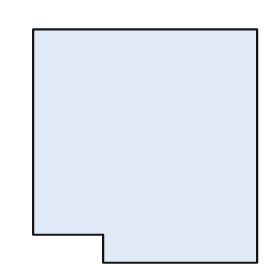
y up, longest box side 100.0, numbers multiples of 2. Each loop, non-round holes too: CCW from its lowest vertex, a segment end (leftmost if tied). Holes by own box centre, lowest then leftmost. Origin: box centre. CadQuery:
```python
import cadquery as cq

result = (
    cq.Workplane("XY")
    .moveTo(-18.0, -50.0)
    .lineTo(48.0, -50.0)
    .lineTo(48.0, 50.0)
    .lineTo(-48.0, 50.0)
    .lineTo(-48.0, -38.0)
    .lineTo(-18.0, -38.0)
    .close()
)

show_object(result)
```